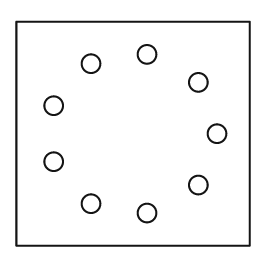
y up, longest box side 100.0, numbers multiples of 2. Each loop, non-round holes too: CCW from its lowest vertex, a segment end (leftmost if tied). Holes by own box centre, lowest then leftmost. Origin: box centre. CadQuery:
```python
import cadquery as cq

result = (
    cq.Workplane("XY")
    .moveTo(-50.0, -48.0)
    .lineTo(50.0, -48.0)
    .lineTo(50.0, 48.0)
    .lineTo(-50.0, 48.0)
    .close()
    .moveTo(6.0, -34.0)
    .circle(4.0)
    .moveTo(-18.0, -30.0)
    .circle(4.0)
    .moveTo(28.0, -22.0)
    .circle(4.0)
    .moveTo(-34.0, -12.0)
    .circle(4.0)
    .moveTo(36.0, 0.0)
    .circle(4.0)
    .moveTo(-34.0, 12.0)
    .circle(4.0)
    .moveTo(28.0, 22.0)
    .circle(4.0)
    .moveTo(-18.0, 30.0)
    .circle(4.0)
    .moveTo(6.0, 34.0)
    .circle(4.0)
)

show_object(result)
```